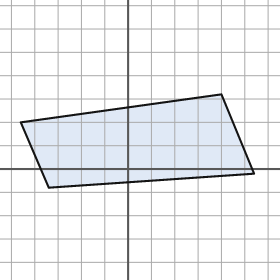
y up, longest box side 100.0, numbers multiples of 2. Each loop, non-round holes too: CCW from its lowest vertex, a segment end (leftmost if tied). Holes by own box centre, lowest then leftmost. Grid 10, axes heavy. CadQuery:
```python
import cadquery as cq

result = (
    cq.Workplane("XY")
    .moveTo(-34.0, -8.0)
    .lineTo(54.0, -2.0)
    .lineTo(40.0, 32.0)
    .lineTo(-46.0, 20.0)
    .close()
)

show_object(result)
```